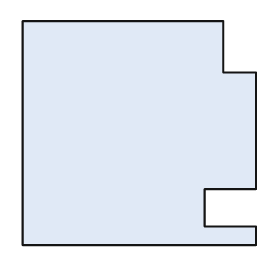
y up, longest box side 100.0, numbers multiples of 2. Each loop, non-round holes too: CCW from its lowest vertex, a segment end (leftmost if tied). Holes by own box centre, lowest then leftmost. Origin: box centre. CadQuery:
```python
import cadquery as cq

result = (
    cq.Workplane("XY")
    .moveTo(-50.0, -48.0)
    .lineTo(50.0, -48.0)
    .lineTo(50.0, -40.0)
    .lineTo(28.0, -40.0)
    .lineTo(28.0, -24.0)
    .lineTo(50.0, -24.0)
    .lineTo(50.0, 26.0)
    .lineTo(36.0, 26.0)
    .lineTo(36.0, 48.0)
    .lineTo(-50.0, 48.0)
    .close()
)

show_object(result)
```